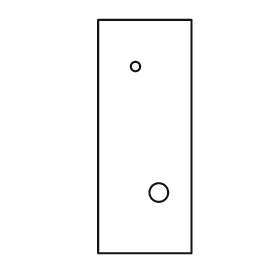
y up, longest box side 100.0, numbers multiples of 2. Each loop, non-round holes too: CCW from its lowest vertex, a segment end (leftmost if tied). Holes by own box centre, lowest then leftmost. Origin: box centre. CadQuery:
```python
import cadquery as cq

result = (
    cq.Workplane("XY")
    .moveTo(-20.0, -50.0)
    .lineTo(20.0, -50.0)
    .lineTo(20.0, 50.0)
    .lineTo(-20.0, 50.0)
    .close()
    .moveTo(6.0, -24.0)
    .circle(4.0)
    .moveTo(-4.0, 30.0)
    .circle(2.0)
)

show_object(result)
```